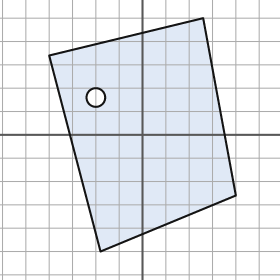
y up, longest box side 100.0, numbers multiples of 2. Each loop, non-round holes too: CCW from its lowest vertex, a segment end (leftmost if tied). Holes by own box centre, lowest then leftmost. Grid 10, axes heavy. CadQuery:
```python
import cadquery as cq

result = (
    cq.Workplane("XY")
    .moveTo(-18.0, -50.0)
    .lineTo(40.0, -26.0)
    .lineTo(26.0, 50.0)
    .lineTo(-40.0, 34.0)
    .close()
    .moveTo(-20.0, 16.0)
    .circle(4.0)
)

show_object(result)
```